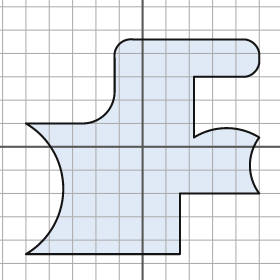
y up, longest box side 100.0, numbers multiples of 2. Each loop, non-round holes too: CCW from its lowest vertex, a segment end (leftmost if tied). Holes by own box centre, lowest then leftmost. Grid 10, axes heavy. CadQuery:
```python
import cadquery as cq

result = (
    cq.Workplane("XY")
    .moveTo(-50.0, -46.0)
    .lineTo(16.0, -46.0)
    .lineTo(16.0, -20.0)
    .lineTo(50.0, -20.0)
    .threePointArc((46.0, -8.0), (50.0, 4.0))
    .threePointArc((36.0, 8.0), (22.0, 4.0))
    .lineTo(22.0, 30.0)
    .lineTo(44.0, 30.0)
    .threePointArc((48.0, 32.0), (50.0, 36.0))
    .lineTo(50.0, 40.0)
    .threePointArc((48.0, 44.0), (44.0, 46.0))
    .lineTo(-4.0, 46.0)
    .threePointArc((-10.0, 44.0), (-12.0, 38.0))
    .lineTo(-12.0, 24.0)
    .threePointArc((-16.0, 14.0), (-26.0, 10.0))
    .lineTo(-50.0, 10.0)
    .threePointArc((-34.0, -18.0), (-50.0, -46.0))
    .close()
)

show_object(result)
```